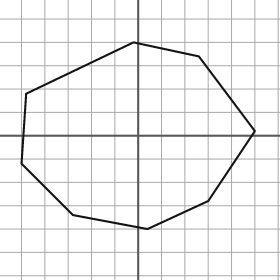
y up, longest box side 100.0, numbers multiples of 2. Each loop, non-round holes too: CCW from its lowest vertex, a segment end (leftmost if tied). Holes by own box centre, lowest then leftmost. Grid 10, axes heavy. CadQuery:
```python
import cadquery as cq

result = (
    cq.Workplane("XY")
    .moveTo(4.0, -40.0)
    .lineTo(30.0, -28.0)
    .lineTo(50.0, 2.0)
    .lineTo(26.0, 34.0)
    .lineTo(-2.0, 40.0)
    .lineTo(-48.0, 18.0)
    .lineTo(-50.0, -12.0)
    .lineTo(-28.0, -34.0)
    .close()
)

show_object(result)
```